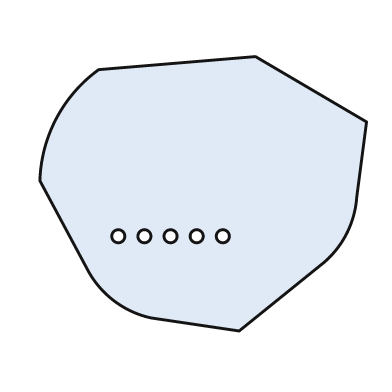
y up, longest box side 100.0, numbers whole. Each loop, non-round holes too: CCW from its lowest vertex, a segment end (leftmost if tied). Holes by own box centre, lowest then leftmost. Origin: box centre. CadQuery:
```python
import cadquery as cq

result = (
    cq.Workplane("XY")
    .moveTo(11.0, -42.0)
    .lineTo(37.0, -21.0)
    .threePointArc((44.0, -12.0), (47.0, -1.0))
    .lineTo(50.0, 22.0)
    .lineTo(16.0, 42.0)
    .lineTo(-32.0, 38.0)
    .threePointArc((-45.0, 23.0), (-50.0, 4.0))
    .lineTo(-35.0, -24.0)
    .threePointArc((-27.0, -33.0), (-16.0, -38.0))
    .close()
    .moveTo(-26.0, -13.0)
    .circle(2.0)
    .moveTo(-18.0, -13.0)
    .circle(2.0)
    .moveTo(-10.0, -13.0)
    .circle(2.0)
    .moveTo(-2.0, -13.0)
    .circle(2.0)
    .moveTo(6.0, -13.0)
    .circle(2.0)
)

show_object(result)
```